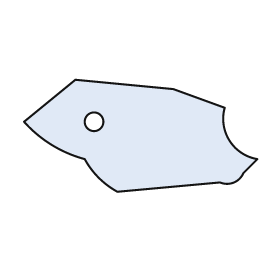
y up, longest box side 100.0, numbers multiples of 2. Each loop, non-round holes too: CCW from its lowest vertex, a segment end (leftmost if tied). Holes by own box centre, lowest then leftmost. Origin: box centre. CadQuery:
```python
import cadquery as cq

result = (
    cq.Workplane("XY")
    .moveTo(-10.0, -24.0)
    .lineTo(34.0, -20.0)
    .threePointArc((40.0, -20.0), (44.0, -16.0))
    .lineTo(50.0, -10.0)
    .threePointArc((38.0, -2.0), (36.0, 12.0))
    .lineTo(14.0, 20.0)
    .lineTo(-28.0, 24.0)
    .lineTo(-50.0, 6.0)
    .threePointArc((-38.0, -4.0), (-24.0, -10.0))
    .threePointArc((-18.0, -18.0), (-10.0, -24.0))
    .close()
    .moveTo(-20.0, 6.0)
    .circle(4.0)
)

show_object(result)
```